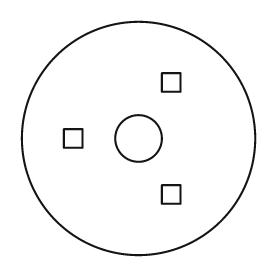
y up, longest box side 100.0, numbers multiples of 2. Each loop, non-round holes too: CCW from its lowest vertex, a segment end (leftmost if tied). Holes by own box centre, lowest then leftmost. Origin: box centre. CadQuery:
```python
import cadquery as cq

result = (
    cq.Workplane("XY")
    .moveTo(0.0, 0.0)
    .circle(50.0)
    .moveTo(10.0, -28.0)
    .lineTo(18.0, -28.0)
    .lineTo(18.0, -20.0)
    .lineTo(10.0, -20.0)
    .close()
    .moveTo(-32.0, -4.0)
    .lineTo(-24.0, -4.0)
    .lineTo(-24.0, 4.0)
    .lineTo(-32.0, 4.0)
    .close()
    .moveTo(0.0, 0.0)
    .circle(10.0)
    .moveTo(10.0, 20.0)
    .lineTo(18.0, 20.0)
    .lineTo(18.0, 28.0)
    .lineTo(10.0, 28.0)
    .close()
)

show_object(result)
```